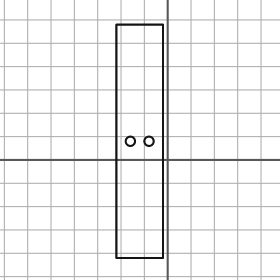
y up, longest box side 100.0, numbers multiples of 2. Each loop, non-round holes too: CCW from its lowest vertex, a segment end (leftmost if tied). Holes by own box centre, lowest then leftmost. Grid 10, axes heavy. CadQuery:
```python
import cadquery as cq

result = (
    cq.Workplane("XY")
    .moveTo(-22.0, -42.0)
    .lineTo(-2.0, -42.0)
    .lineTo(-2.0, 58.0)
    .lineTo(-22.0, 58.0)
    .close()
    .moveTo(-16.0, 8.0)
    .circle(2.0)
    .moveTo(-8.0, 8.0)
    .circle(2.0)
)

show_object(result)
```